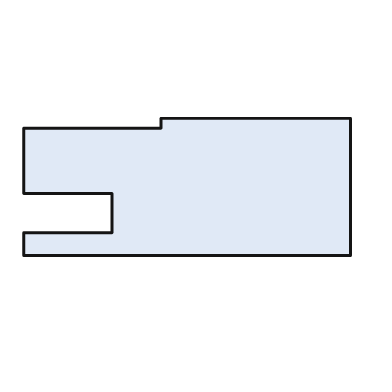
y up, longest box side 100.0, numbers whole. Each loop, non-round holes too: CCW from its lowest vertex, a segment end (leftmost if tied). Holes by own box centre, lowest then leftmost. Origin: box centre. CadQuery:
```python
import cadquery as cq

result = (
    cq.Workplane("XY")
    .moveTo(-50.0, -21.0)
    .lineTo(50.0, -21.0)
    .lineTo(50.0, 21.0)
    .lineTo(-8.0, 21.0)
    .lineTo(-8.0, 18.0)
    .lineTo(-50.0, 18.0)
    .lineTo(-50.0, -2.0)
    .lineTo(-23.0, -2.0)
    .lineTo(-23.0, -14.0)
    .lineTo(-50.0, -14.0)
    .close()
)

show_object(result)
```